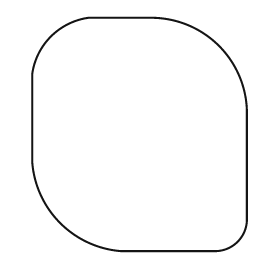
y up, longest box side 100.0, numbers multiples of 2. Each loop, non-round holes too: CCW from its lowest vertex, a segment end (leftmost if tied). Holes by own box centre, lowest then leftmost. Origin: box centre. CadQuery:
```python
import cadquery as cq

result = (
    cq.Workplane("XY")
    .moveTo(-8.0, -50.0)
    .lineTo(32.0, -50.0)
    .threePointArc((42.0, -46.0), (46.0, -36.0))
    .lineTo(46.0, 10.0)
    .threePointArc((34.0, 38.0), (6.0, 50.0))
    .lineTo(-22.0, 50.0)
    .threePointArc((-38.0, 42.0), (-46.0, 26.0))
    .lineTo(-46.0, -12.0)
    .threePointArc((-34.0, -38.0), (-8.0, -50.0))
    .close()
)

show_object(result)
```